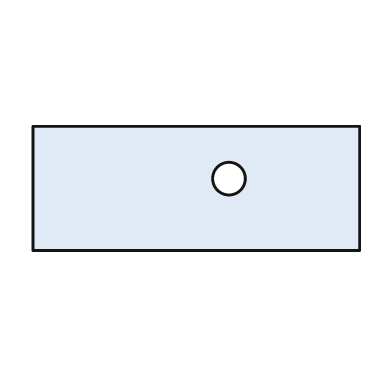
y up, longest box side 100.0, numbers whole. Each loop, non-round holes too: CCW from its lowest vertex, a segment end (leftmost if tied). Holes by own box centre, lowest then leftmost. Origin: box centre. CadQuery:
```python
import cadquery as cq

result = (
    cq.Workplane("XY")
    .moveTo(-50.0, -19.0)
    .lineTo(50.0, -19.0)
    .lineTo(50.0, 19.0)
    .lineTo(-50.0, 19.0)
    .close()
    .moveTo(10.0, 3.0)
    .circle(5.0)
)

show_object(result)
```